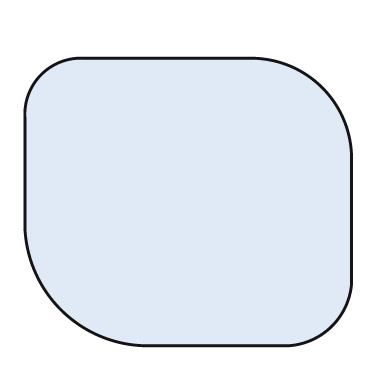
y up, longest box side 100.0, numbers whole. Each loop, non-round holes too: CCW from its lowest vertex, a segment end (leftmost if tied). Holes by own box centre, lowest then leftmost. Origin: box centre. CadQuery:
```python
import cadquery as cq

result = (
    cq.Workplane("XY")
    .moveTo(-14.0, -44.0)
    .lineTo(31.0, -44.0)
    .threePointArc((44.0, -38.0), (50.0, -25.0))
    .lineTo(50.0, 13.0)
    .threePointArc((41.0, 35.0), (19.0, 44.0))
    .lineTo(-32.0, 44.0)
    .threePointArc((-45.0, 39.0), (-50.0, 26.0))
    .lineTo(-50.0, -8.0)
    .threePointArc((-39.0, -33.0), (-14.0, -44.0))
    .close()
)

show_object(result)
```